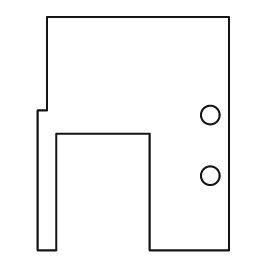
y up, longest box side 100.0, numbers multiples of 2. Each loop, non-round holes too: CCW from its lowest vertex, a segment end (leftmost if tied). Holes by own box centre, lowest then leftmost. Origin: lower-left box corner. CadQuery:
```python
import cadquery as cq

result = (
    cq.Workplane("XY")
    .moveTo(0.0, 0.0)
    .lineTo(8.0, 0.0)
    .lineTo(8.0, 50.0)
    .lineTo(48.0, 50.0)
    .lineTo(48.0, 0.0)
    .lineTo(82.0, 0.0)
    .lineTo(82.0, 100.0)
    .lineTo(4.0, 100.0)
    .lineTo(4.0, 60.0)
    .lineTo(0.0, 60.0)
    .close()
    .moveTo(74.0, 32.0)
    .circle(4.0)
    .moveTo(74.0, 58.0)
    .circle(4.0)
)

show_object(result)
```